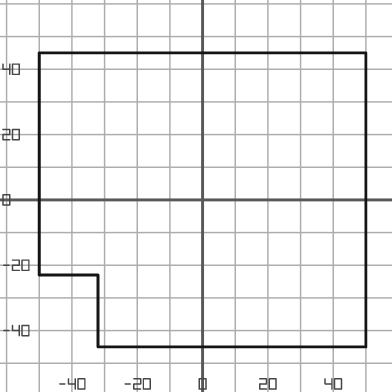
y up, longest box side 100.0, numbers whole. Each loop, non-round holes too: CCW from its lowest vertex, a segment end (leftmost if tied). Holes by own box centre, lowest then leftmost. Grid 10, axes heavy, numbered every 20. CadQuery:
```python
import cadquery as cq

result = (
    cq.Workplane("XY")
    .moveTo(-32.0, -45.0)
    .lineTo(50.0, -45.0)
    .lineTo(50.0, 45.0)
    .lineTo(-50.0, 45.0)
    .lineTo(-50.0, -23.0)
    .lineTo(-32.0, -23.0)
    .close()
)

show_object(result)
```